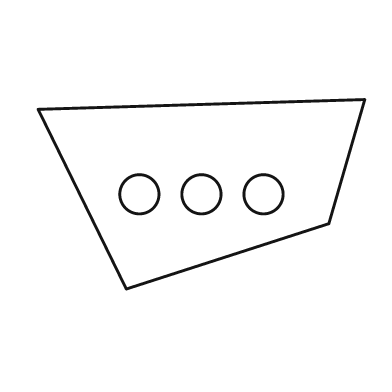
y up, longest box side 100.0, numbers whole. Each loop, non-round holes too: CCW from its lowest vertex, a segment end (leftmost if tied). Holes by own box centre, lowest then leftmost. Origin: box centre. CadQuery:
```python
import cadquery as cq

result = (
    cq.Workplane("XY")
    .moveTo(-23.0, -29.0)
    .lineTo(39.0, -9.0)
    .lineTo(50.0, 29.0)
    .lineTo(-50.0, 26.0)
    .close()
    .moveTo(-19.0, 0.0)
    .circle(6.0)
    .moveTo(0.0, 0.0)
    .circle(6.0)
    .moveTo(19.0, 0.0)
    .circle(6.0)
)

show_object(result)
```